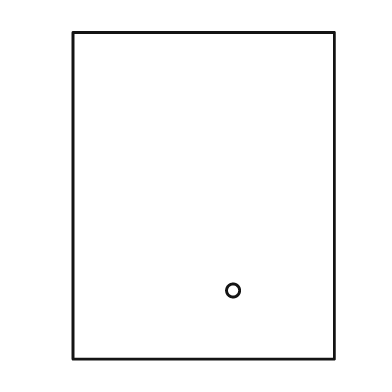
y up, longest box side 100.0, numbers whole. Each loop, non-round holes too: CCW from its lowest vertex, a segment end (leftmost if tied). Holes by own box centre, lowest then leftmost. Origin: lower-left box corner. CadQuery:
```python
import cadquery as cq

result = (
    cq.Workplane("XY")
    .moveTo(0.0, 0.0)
    .lineTo(80.0, 0.0)
    .lineTo(80.0, 100.0)
    .lineTo(0.0, 100.0)
    .close()
    .moveTo(49.0, 21.0)
    .circle(2.0)
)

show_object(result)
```